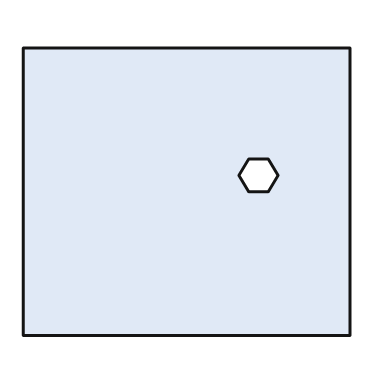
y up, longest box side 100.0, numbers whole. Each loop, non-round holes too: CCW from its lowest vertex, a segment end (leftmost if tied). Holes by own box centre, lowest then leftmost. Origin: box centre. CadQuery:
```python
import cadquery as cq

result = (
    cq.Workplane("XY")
    .moveTo(-50.0, -44.0)
    .lineTo(50.0, -44.0)
    .lineTo(50.0, 44.0)
    .lineTo(-50.0, 44.0)
    .close()
    .moveTo(19.0, 0.0)
    .lineTo(25.0, 0.0)
    .lineTo(28.0, 5.0)
    .lineTo(25.0, 10.0)
    .lineTo(19.0, 10.0)
    .lineTo(16.0, 5.0)
    .close()
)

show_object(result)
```